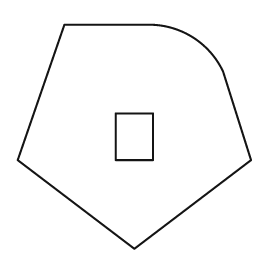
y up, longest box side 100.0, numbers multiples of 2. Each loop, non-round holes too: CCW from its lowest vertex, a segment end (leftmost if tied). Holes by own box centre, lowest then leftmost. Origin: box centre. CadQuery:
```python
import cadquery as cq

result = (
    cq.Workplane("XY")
    .moveTo(0.0, -48.0)
    .lineTo(50.0, -10.0)
    .lineTo(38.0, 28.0)
    .threePointArc((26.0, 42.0), (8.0, 48.0))
    .lineTo(-30.0, 48.0)
    .lineTo(-50.0, -10.0)
    .close()
    .moveTo(-8.0, -10.0)
    .lineTo(8.0, -10.0)
    .lineTo(8.0, 10.0)
    .lineTo(-8.0, 10.0)
    .close()
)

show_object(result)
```